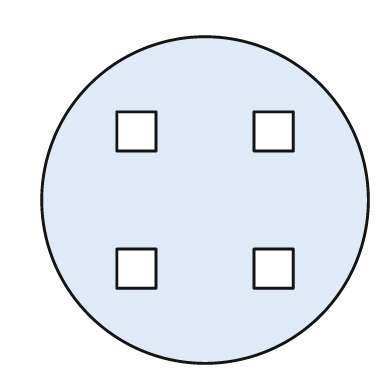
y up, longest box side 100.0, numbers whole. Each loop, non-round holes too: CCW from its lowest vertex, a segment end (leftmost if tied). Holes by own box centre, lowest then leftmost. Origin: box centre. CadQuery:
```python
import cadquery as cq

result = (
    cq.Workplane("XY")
    .moveTo(0.0, 0.0)
    .circle(50.0)
    .moveTo(-27.0, -27.0)
    .lineTo(-15.0, -27.0)
    .lineTo(-15.0, -15.0)
    .lineTo(-27.0, -15.0)
    .close()
    .moveTo(15.0, -27.0)
    .lineTo(27.0, -27.0)
    .lineTo(27.0, -15.0)
    .lineTo(15.0, -15.0)
    .close()
    .moveTo(-27.0, 15.0)
    .lineTo(-15.0, 15.0)
    .lineTo(-15.0, 27.0)
    .lineTo(-27.0, 27.0)
    .close()
    .moveTo(15.0, 15.0)
    .lineTo(27.0, 15.0)
    .lineTo(27.0, 27.0)
    .lineTo(15.0, 27.0)
    .close()
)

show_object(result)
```